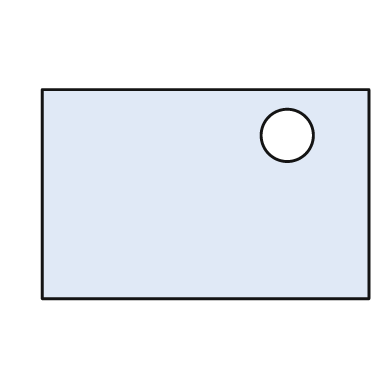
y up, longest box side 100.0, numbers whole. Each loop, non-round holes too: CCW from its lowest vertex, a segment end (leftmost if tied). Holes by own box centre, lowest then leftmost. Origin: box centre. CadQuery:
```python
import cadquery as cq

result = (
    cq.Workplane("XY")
    .moveTo(-50.0, -32.0)
    .lineTo(50.0, -32.0)
    .lineTo(50.0, 32.0)
    .lineTo(-50.0, 32.0)
    .close()
    .moveTo(25.0, 18.0)
    .circle(8.0)
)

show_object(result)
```